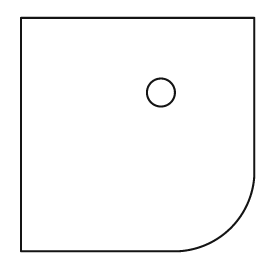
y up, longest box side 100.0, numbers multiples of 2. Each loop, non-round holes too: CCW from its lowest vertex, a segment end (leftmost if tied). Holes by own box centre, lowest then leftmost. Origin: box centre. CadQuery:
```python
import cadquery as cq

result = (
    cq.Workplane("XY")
    .moveTo(-50.0, -50.0)
    .lineTo(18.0, -50.0)
    .threePointArc((40.0, -40.0), (50.0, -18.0))
    .lineTo(50.0, 50.0)
    .lineTo(-50.0, 50.0)
    .close()
    .moveTo(10.0, 18.0)
    .circle(6.0)
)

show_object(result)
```